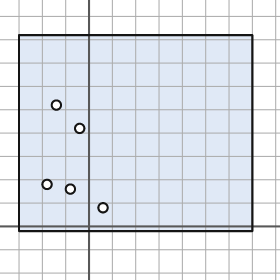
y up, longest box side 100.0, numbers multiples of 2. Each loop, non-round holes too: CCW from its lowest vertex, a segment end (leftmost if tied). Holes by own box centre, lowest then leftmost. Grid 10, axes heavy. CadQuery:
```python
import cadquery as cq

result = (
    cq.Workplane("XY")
    .moveTo(-30.0, -2.0)
    .lineTo(70.0, -2.0)
    .lineTo(70.0, 82.0)
    .lineTo(-30.0, 82.0)
    .close()
    .moveTo(6.0, 8.0)
    .circle(2.0)
    .moveTo(-8.0, 16.0)
    .circle(2.0)
    .moveTo(-18.0, 18.0)
    .circle(2.0)
    .moveTo(-4.0, 42.0)
    .circle(2.0)
    .moveTo(-14.0, 52.0)
    .circle(2.0)
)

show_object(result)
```